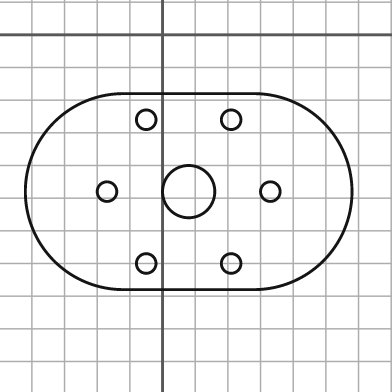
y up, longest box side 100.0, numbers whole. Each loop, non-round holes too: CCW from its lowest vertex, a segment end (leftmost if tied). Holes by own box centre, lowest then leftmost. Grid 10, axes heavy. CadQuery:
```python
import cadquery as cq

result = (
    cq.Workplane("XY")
    .moveTo(-12.0, -78.0)
    .lineTo(28.0, -78.0)
    .threePointArc((58.0, -48.0), (28.0, -18.0))
    .lineTo(-12.0, -18.0)
    .threePointArc((-42.0, -48.0), (-12.0, -78.0))
    .close()
    .moveTo(-5.0, -70.0)
    .circle(3.0)
    .moveTo(21.0, -70.0)
    .circle(3.0)
    .moveTo(-17.0, -48.0)
    .circle(3.0)
    .moveTo(8.0, -48.0)
    .circle(8.0)
    .moveTo(33.0, -48.0)
    .circle(3.0)
    .moveTo(-5.0, -26.0)
    .circle(3.0)
    .moveTo(21.0, -26.0)
    .circle(3.0)
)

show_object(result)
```